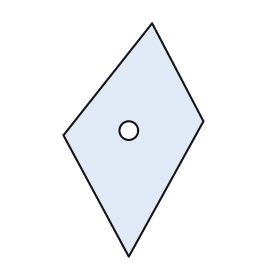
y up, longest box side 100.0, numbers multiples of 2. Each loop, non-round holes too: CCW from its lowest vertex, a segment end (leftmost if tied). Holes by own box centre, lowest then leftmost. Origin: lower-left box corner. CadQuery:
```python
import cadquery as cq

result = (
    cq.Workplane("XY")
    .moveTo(28.0, 0.0)
    .lineTo(60.0, 58.0)
    .lineTo(38.0, 100.0)
    .lineTo(0.0, 52.0)
    .close()
    .moveTo(28.0, 54.0)
    .circle(4.0)
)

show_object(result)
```